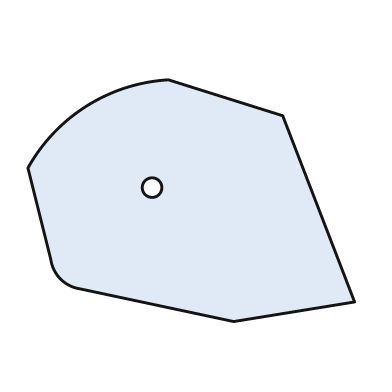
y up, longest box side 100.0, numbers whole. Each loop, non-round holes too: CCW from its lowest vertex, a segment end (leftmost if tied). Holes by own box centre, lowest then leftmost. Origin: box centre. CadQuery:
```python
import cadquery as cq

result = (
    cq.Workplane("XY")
    .moveTo(13.0, -37.0)
    .lineTo(50.0, -31.0)
    .lineTo(28.0, 26.0)
    .lineTo(-7.0, 37.0)
    .threePointArc((-32.0, 29.0), (-50.0, 10.0))
    .lineTo(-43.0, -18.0)
    .threePointArc((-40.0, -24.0), (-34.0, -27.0))
    .close()
    .moveTo(-12.0, 4.0)
    .circle(3.0)
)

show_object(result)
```